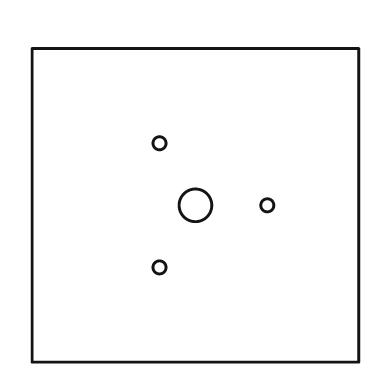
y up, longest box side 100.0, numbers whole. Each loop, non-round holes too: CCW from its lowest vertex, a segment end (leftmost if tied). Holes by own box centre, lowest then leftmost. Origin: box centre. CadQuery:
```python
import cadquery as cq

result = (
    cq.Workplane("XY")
    .moveTo(-50.0, -48.0)
    .lineTo(50.0, -48.0)
    .lineTo(50.0, 48.0)
    .lineTo(-50.0, 48.0)
    .close()
    .moveTo(-11.0, -19.0)
    .circle(2.0)
    .moveTo(0.0, 0.0)
    .circle(5.0)
    .moveTo(22.0, 0.0)
    .circle(2.0)
    .moveTo(-11.0, 19.0)
    .circle(2.0)
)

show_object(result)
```